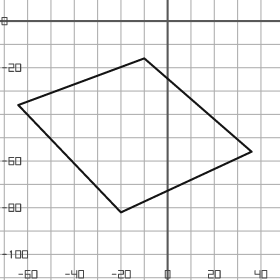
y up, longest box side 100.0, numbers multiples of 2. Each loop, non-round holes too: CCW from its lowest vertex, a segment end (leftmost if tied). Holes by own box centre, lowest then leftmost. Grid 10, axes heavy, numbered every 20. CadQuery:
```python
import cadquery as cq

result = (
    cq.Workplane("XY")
    .moveTo(-20.0, -82.0)
    .lineTo(36.0, -56.0)
    .lineTo(-10.0, -16.0)
    .lineTo(-64.0, -36.0)
    .close()
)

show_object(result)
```